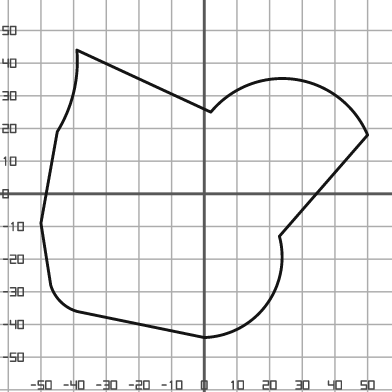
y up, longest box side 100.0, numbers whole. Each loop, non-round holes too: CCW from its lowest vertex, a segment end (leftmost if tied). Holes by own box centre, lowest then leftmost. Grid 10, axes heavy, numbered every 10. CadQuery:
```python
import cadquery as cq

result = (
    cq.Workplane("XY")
    .moveTo(0.0, -44.0)
    .threePointArc((19.0, -34.0), (23.0, -13.0))
    .lineTo(50.0, 18.0)
    .threePointArc((28.0, 35.0), (2.0, 25.0))
    .lineTo(-39.0, 44.0)
    .threePointArc((-40.0, 31.0), (-45.0, 19.0))
    .lineTo(-50.0, -9.0)
    .lineTo(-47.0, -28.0)
    .threePointArc((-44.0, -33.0), (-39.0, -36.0))
    .close()
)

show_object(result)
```